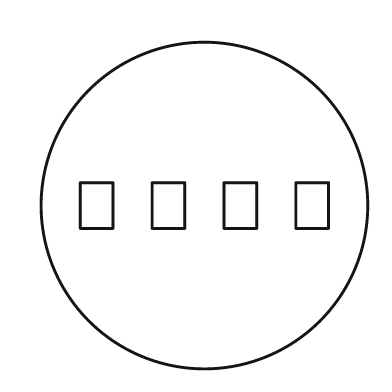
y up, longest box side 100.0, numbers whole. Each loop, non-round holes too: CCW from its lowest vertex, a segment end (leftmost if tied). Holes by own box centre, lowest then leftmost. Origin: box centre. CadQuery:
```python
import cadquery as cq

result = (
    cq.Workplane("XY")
    .moveTo(0.0, 0.0)
    .circle(50.0)
    .moveTo(-38.0, -7.0)
    .lineTo(-28.0, -7.0)
    .lineTo(-28.0, 7.0)
    .lineTo(-38.0, 7.0)
    .close()
    .moveTo(-16.0, -7.0)
    .lineTo(-6.0, -7.0)
    .lineTo(-6.0, 7.0)
    .lineTo(-16.0, 7.0)
    .close()
    .moveTo(6.0, -7.0)
    .lineTo(16.0, -7.0)
    .lineTo(16.0, 7.0)
    .lineTo(6.0, 7.0)
    .close()
    .moveTo(28.0, -7.0)
    .lineTo(38.0, -7.0)
    .lineTo(38.0, 7.0)
    .lineTo(28.0, 7.0)
    .close()
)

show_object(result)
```